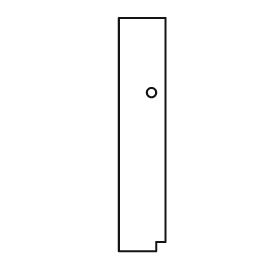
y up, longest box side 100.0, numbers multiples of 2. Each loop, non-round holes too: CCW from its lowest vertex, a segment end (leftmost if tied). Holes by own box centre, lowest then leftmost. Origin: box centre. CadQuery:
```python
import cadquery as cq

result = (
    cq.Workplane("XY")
    .moveTo(-10.0, -50.0)
    .lineTo(6.0, -50.0)
    .lineTo(6.0, -46.0)
    .lineTo(10.0, -46.0)
    .lineTo(10.0, 50.0)
    .lineTo(-10.0, 50.0)
    .close()
    .moveTo(4.0, 18.0)
    .circle(2.0)
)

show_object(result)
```